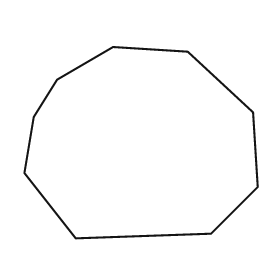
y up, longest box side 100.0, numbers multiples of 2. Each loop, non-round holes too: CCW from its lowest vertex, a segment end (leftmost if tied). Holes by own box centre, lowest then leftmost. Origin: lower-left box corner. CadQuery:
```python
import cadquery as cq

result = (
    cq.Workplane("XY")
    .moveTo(22.0, 0.0)
    .lineTo(80.0, 2.0)
    .lineTo(100.0, 22.0)
    .lineTo(98.0, 54.0)
    .lineTo(70.0, 80.0)
    .lineTo(38.0, 82.0)
    .lineTo(14.0, 68.0)
    .lineTo(4.0, 52.0)
    .lineTo(0.0, 28.0)
    .close()
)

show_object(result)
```